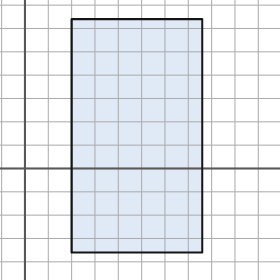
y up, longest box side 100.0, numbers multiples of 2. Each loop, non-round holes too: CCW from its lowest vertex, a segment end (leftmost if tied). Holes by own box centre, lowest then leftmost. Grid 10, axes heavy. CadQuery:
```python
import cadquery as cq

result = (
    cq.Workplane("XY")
    .moveTo(20.0, -36.0)
    .lineTo(76.0, -36.0)
    .lineTo(76.0, 64.0)
    .lineTo(20.0, 64.0)
    .close()
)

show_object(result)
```